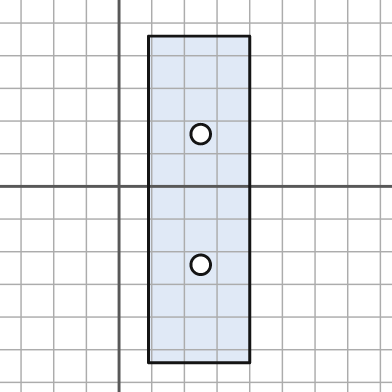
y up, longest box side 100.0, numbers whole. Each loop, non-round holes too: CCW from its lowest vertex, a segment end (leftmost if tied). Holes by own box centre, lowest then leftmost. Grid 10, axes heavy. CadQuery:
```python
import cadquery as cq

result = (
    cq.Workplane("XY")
    .moveTo(9.0, -54.0)
    .lineTo(40.0, -54.0)
    .lineTo(40.0, 46.0)
    .lineTo(9.0, 46.0)
    .close()
    .moveTo(25.0, -24.0)
    .circle(3.0)
    .moveTo(25.0, 16.0)
    .circle(3.0)
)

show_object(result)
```